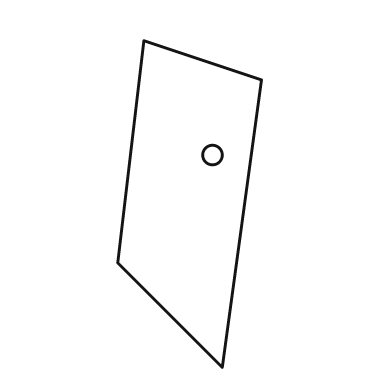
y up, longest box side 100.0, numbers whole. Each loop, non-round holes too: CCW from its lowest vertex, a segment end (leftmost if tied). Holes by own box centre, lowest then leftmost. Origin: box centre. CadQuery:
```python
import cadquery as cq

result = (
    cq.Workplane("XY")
    .moveTo(10.0, -50.0)
    .lineTo(22.0, 38.0)
    .lineTo(-14.0, 50.0)
    .lineTo(-22.0, -18.0)
    .close()
    .moveTo(7.0, 15.0)
    .circle(3.0)
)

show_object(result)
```